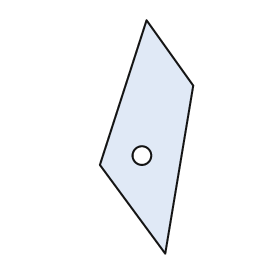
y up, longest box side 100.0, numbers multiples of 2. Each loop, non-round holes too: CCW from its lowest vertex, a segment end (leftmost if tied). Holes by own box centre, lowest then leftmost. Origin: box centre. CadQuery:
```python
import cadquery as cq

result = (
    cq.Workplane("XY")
    .moveTo(8.0, -50.0)
    .lineTo(20.0, 22.0)
    .lineTo(0.0, 50.0)
    .lineTo(-20.0, -12.0)
    .close()
    .moveTo(-2.0, -8.0)
    .circle(4.0)
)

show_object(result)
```